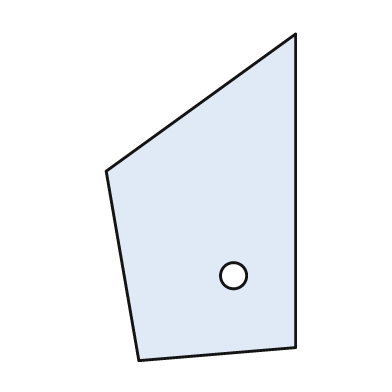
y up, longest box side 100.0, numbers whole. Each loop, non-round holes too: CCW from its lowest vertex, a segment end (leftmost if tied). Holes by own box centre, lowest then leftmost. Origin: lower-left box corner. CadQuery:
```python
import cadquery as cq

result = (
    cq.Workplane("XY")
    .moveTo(10.0, 0.0)
    .lineTo(58.0, 4.0)
    .lineTo(58.0, 100.0)
    .lineTo(0.0, 58.0)
    .close()
    .moveTo(39.0, 26.0)
    .circle(4.0)
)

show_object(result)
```